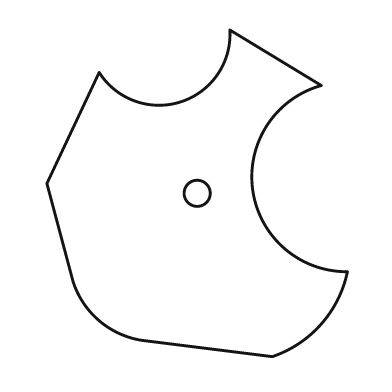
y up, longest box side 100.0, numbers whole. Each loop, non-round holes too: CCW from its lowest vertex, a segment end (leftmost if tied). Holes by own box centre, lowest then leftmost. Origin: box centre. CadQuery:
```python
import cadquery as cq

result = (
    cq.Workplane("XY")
    .moveTo(23.0, -50.0)
    .threePointArc((38.0, -40.0), (46.0, -24.0))
    .threePointArc((17.0, 1.0), (38.0, 33.0))
    .lineTo(10.0, 50.0)
    .threePointArc((-5.0, 28.0), (-30.0, 37.0))
    .lineTo(-46.0, 3.0)
    .lineTo(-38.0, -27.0)
    .threePointArc((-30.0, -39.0), (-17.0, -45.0))
    .close()
    .moveTo(0.0, 0.0)
    .circle(4.0)
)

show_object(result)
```